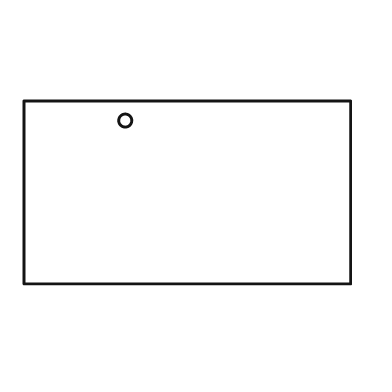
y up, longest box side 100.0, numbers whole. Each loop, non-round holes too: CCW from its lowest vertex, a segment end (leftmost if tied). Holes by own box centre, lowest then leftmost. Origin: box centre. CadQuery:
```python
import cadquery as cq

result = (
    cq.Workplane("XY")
    .moveTo(-50.0, -28.0)
    .lineTo(50.0, -28.0)
    .lineTo(50.0, 28.0)
    .lineTo(-50.0, 28.0)
    .close()
    .moveTo(-19.0, 22.0)
    .circle(2.0)
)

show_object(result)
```